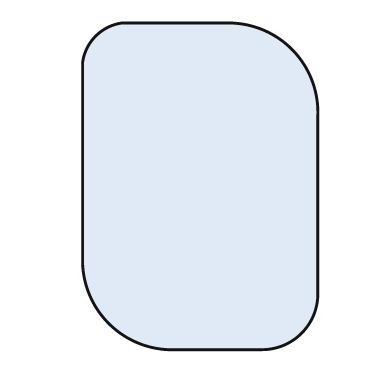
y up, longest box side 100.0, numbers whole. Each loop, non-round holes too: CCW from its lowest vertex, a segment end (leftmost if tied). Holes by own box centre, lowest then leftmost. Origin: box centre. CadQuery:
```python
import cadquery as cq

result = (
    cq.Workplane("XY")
    .moveTo(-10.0, -50.0)
    .lineTo(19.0, -50.0)
    .threePointArc((31.0, -45.0), (36.0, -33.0))
    .lineTo(36.0, 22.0)
    .threePointArc((28.0, 42.0), (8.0, 50.0))
    .lineTo(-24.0, 50.0)
    .threePointArc((-32.0, 46.0), (-36.0, 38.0))
    .lineTo(-36.0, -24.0)
    .threePointArc((-28.0, -42.0), (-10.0, -50.0))
    .close()
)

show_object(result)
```